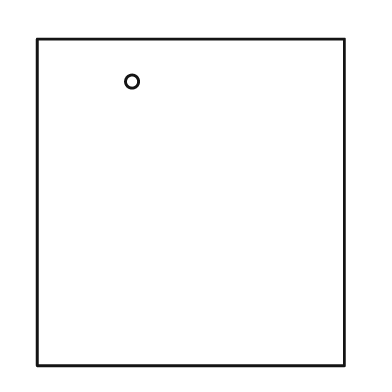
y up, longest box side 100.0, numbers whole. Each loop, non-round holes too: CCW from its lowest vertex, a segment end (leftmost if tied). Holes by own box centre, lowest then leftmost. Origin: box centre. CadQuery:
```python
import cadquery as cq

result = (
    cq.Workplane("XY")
    .moveTo(-47.0, -50.0)
    .lineTo(47.0, -50.0)
    .lineTo(47.0, 50.0)
    .lineTo(-47.0, 50.0)
    .close()
    .moveTo(-18.0, 37.0)
    .circle(2.0)
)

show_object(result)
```